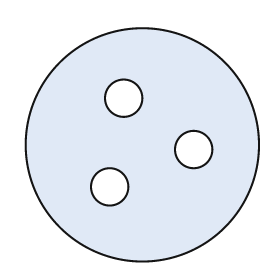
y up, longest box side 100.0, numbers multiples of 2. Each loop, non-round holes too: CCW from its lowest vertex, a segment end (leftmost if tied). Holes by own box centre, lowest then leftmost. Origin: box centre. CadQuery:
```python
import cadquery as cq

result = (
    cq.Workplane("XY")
    .moveTo(0.0, 0.0)
    .circle(50.0)
    .moveTo(-14.0, -18.0)
    .circle(8.0)
    .moveTo(22.0, -2.0)
    .circle(8.0)
    .moveTo(-8.0, 20.0)
    .circle(8.0)
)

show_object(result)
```